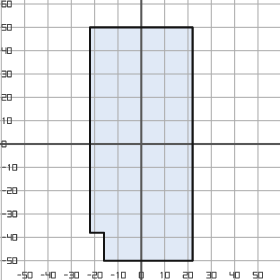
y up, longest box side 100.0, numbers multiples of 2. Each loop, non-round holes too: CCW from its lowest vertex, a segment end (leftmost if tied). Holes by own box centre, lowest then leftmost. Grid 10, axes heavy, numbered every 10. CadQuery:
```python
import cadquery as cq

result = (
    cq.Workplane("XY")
    .moveTo(-16.0, -50.0)
    .lineTo(22.0, -50.0)
    .lineTo(22.0, 50.0)
    .lineTo(-22.0, 50.0)
    .lineTo(-22.0, -38.0)
    .lineTo(-16.0, -38.0)
    .close()
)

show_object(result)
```